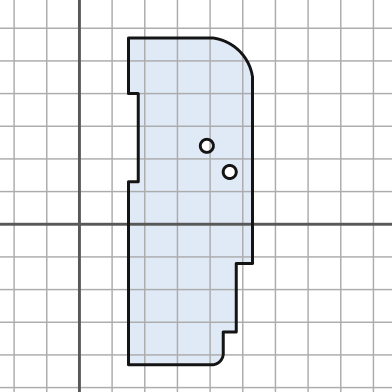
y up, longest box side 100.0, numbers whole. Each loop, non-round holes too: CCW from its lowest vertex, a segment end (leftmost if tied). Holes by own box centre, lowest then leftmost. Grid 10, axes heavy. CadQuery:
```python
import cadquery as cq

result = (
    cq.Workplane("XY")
    .moveTo(15.0, -43.0)
    .lineTo(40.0, -43.0)
    .threePointArc((43.0, -42.0), (44.0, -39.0))
    .lineTo(44.0, -33.0)
    .lineTo(48.0, -33.0)
    .lineTo(48.0, -12.0)
    .lineTo(53.0, -12.0)
    .lineTo(53.0, 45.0)
    .threePointArc((49.0, 53.0), (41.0, 57.0))
    .lineTo(15.0, 57.0)
    .lineTo(15.0, 40.0)
    .lineTo(18.0, 40.0)
    .lineTo(18.0, 13.0)
    .lineTo(15.0, 13.0)
    .close()
    .moveTo(46.0, 16.0)
    .circle(2.0)
    .moveTo(39.0, 24.0)
    .circle(2.0)
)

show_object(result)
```